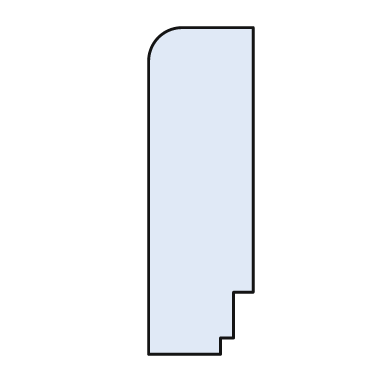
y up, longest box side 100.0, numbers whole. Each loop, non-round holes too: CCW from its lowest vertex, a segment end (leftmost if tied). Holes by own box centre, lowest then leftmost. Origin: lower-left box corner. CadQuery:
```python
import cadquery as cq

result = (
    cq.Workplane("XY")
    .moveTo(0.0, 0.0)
    .lineTo(22.0, 0.0)
    .lineTo(22.0, 5.0)
    .lineTo(26.0, 5.0)
    .lineTo(26.0, 19.0)
    .lineTo(32.0, 19.0)
    .lineTo(32.0, 100.0)
    .lineTo(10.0, 100.0)
    .threePointArc((3.0, 97.0), (0.0, 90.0))
    .close()
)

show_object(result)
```